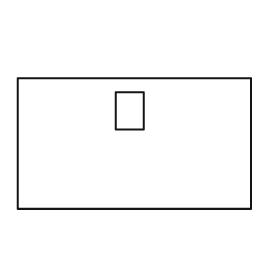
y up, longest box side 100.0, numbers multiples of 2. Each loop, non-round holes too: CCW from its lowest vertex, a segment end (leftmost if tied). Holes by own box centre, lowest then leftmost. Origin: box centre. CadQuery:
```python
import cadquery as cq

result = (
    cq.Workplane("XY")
    .moveTo(-50.0, -28.0)
    .lineTo(50.0, -28.0)
    .lineTo(50.0, 28.0)
    .lineTo(-50.0, 28.0)
    .close()
    .moveTo(-8.0, 6.0)
    .lineTo(4.0, 6.0)
    .lineTo(4.0, 22.0)
    .lineTo(-8.0, 22.0)
    .close()
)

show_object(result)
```